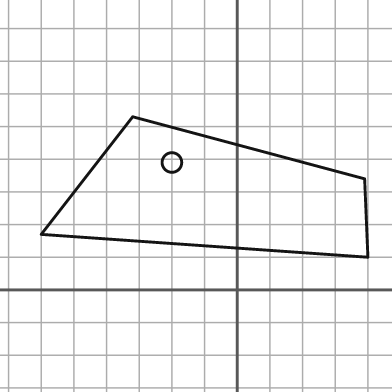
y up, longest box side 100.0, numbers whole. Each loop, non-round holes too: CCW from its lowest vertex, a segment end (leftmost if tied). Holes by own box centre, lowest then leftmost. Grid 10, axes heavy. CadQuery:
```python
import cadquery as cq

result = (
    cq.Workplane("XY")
    .moveTo(40.0, 10.0)
    .lineTo(39.0, 34.0)
    .lineTo(-32.0, 53.0)
    .lineTo(-60.0, 17.0)
    .close()
    .moveTo(-20.0, 39.0)
    .circle(3.0)
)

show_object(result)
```